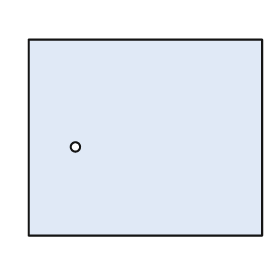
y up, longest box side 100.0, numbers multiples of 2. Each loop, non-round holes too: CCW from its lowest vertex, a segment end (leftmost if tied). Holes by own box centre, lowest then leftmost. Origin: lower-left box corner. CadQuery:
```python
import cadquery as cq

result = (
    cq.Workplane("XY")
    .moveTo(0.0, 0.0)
    .lineTo(100.0, 0.0)
    .lineTo(100.0, 84.0)
    .lineTo(0.0, 84.0)
    .close()
    .moveTo(20.0, 38.0)
    .circle(2.0)
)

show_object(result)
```